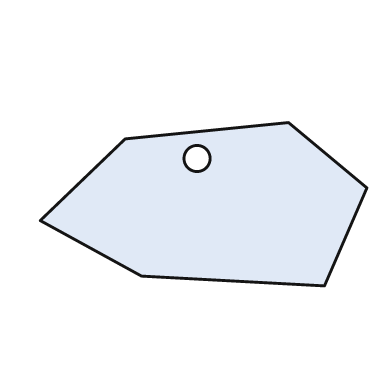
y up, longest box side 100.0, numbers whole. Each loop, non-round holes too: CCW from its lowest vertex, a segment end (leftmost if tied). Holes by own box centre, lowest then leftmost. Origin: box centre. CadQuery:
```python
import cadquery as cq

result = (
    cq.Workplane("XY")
    .moveTo(37.0, -25.0)
    .lineTo(50.0, 5.0)
    .lineTo(26.0, 25.0)
    .lineTo(-24.0, 20.0)
    .lineTo(-50.0, -5.0)
    .lineTo(-19.0, -22.0)
    .close()
    .moveTo(-2.0, 14.0)
    .circle(4.0)
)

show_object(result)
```